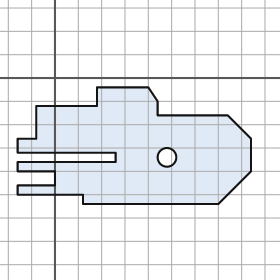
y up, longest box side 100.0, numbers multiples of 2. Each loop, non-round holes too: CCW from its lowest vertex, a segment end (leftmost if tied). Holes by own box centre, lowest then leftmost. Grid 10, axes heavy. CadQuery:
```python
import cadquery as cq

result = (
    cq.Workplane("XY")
    .moveTo(12.0, -54.0)
    .lineTo(70.0, -54.0)
    .lineTo(84.0, -40.0)
    .lineTo(84.0, -26.0)
    .lineTo(74.0, -16.0)
    .lineTo(44.0, -16.0)
    .lineTo(44.0, -10.0)
    .lineTo(40.0, -4.0)
    .lineTo(18.0, -4.0)
    .lineTo(18.0, -12.0)
    .lineTo(-8.0, -12.0)
    .lineTo(-8.0, -26.0)
    .lineTo(-16.0, -26.0)
    .lineTo(-16.0, -32.0)
    .lineTo(26.0, -32.0)
    .lineTo(26.0, -36.0)
    .lineTo(-16.0, -36.0)
    .lineTo(-16.0, -40.0)
    .lineTo(0.0, -40.0)
    .lineTo(0.0, -46.0)
    .lineTo(-16.0, -46.0)
    .lineTo(-16.0, -50.0)
    .lineTo(12.0, -50.0)
    .close()
    .moveTo(48.0, -34.0)
    .circle(4.0)
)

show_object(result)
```